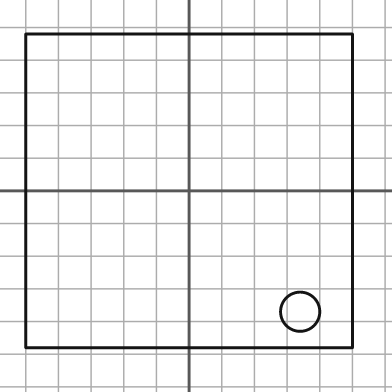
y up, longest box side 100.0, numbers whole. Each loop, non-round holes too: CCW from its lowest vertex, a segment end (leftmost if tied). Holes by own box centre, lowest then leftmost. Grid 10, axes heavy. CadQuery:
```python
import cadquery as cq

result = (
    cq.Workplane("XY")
    .moveTo(-50.0, -48.0)
    .lineTo(50.0, -48.0)
    .lineTo(50.0, 48.0)
    .lineTo(-50.0, 48.0)
    .close()
    .moveTo(34.0, -37.0)
    .circle(6.0)
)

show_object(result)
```